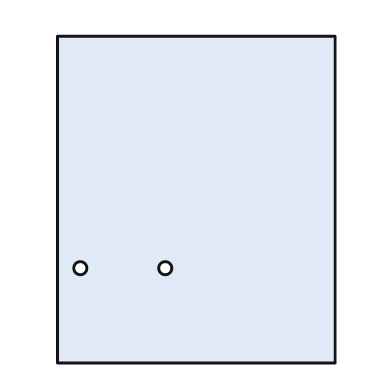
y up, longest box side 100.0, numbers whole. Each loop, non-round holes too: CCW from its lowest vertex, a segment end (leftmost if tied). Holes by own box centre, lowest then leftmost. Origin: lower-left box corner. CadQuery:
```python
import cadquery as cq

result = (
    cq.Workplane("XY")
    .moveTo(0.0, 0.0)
    .lineTo(85.0, 0.0)
    .lineTo(85.0, 100.0)
    .lineTo(0.0, 100.0)
    .close()
    .moveTo(7.0, 29.0)
    .circle(2.0)
    .moveTo(33.0, 29.0)
    .circle(2.0)
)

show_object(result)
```